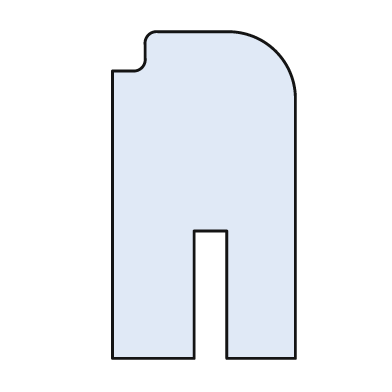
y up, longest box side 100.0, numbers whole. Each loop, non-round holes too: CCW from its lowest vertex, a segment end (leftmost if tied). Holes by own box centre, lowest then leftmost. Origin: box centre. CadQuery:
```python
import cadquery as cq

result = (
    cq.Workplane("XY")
    .moveTo(-28.0, -50.0)
    .lineTo(-3.0, -50.0)
    .lineTo(-3.0, -11.0)
    .lineTo(7.0, -11.0)
    .lineTo(7.0, -50.0)
    .lineTo(28.0, -50.0)
    .lineTo(28.0, 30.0)
    .threePointArc((22.0, 44.0), (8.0, 50.0))
    .lineTo(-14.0, 50.0)
    .threePointArc((-17.0, 49.0), (-18.0, 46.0))
    .lineTo(-18.0, 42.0)
    .threePointArc((-19.0, 39.0), (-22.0, 38.0))
    .lineTo(-28.0, 38.0)
    .close()
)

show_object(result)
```